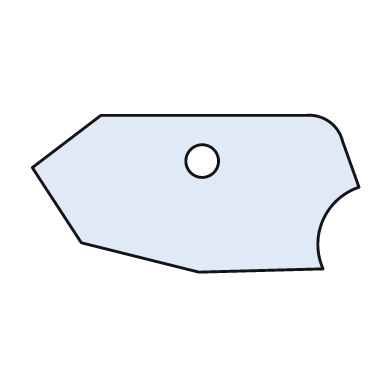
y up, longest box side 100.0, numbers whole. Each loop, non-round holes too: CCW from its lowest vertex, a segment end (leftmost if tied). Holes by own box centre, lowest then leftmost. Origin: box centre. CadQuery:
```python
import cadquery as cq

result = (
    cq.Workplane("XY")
    .moveTo(1.0, -24.0)
    .lineTo(39.0, -23.0)
    .threePointArc((39.0, -8.0), (50.0, 2.0))
    .lineTo(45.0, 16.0)
    .threePointArc((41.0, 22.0), (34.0, 24.0))
    .lineTo(-29.0, 24.0)
    .lineTo(-50.0, 8.0)
    .lineTo(-35.0, -15.0)
    .close()
    .moveTo(2.0, 10.0)
    .circle(5.0)
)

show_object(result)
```